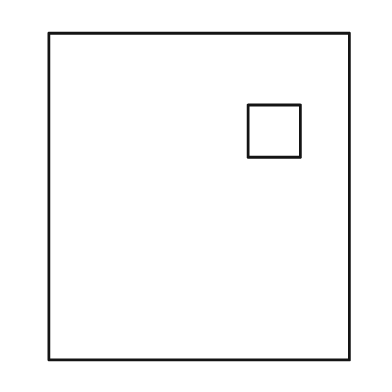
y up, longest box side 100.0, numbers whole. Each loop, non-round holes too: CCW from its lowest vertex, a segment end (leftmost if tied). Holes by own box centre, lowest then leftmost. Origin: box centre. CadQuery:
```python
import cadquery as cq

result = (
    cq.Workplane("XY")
    .moveTo(-46.0, -50.0)
    .lineTo(46.0, -50.0)
    .lineTo(46.0, 50.0)
    .lineTo(-46.0, 50.0)
    .close()
    .moveTo(15.0, 12.0)
    .lineTo(31.0, 12.0)
    .lineTo(31.0, 28.0)
    .lineTo(15.0, 28.0)
    .close()
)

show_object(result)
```